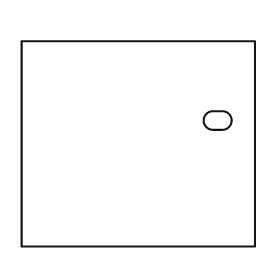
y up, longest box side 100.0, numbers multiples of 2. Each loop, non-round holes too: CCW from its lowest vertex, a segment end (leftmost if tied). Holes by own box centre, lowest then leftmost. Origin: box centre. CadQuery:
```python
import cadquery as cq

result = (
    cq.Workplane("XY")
    .moveTo(-50.0, -44.0)
    .lineTo(50.0, -44.0)
    .lineTo(50.0, 44.0)
    .lineTo(-50.0, 44.0)
    .close()
    .moveTo(32.0, 6.0)
    .lineTo(36.0, 6.0)
    .threePointArc((40.0, 10.0), (36.0, 14.0))
    .lineTo(32.0, 14.0)
    .threePointArc((28.0, 10.0), (32.0, 6.0))
    .close()
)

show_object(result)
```